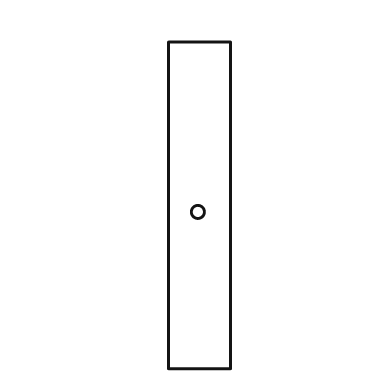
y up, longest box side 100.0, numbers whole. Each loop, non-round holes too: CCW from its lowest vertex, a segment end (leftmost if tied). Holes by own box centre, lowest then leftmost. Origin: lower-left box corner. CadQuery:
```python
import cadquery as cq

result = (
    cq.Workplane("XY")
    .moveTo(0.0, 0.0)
    .lineTo(19.0, 0.0)
    .lineTo(19.0, 100.0)
    .lineTo(0.0, 100.0)
    .close()
    .moveTo(9.0, 48.0)
    .circle(2.0)
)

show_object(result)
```